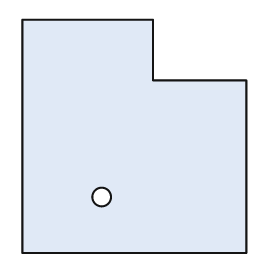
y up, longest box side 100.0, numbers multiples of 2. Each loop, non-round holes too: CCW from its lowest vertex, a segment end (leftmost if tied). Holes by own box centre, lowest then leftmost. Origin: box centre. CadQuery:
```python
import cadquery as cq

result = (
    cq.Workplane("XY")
    .moveTo(-48.0, -50.0)
    .lineTo(48.0, -50.0)
    .lineTo(48.0, 24.0)
    .lineTo(8.0, 24.0)
    .lineTo(8.0, 50.0)
    .lineTo(-48.0, 50.0)
    .close()
    .moveTo(-14.0, -26.0)
    .circle(4.0)
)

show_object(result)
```